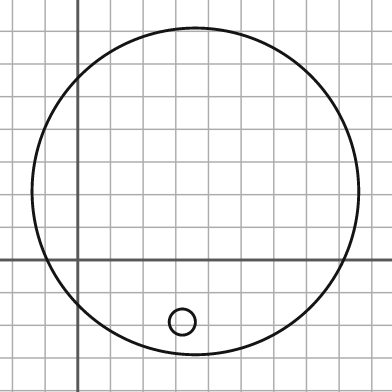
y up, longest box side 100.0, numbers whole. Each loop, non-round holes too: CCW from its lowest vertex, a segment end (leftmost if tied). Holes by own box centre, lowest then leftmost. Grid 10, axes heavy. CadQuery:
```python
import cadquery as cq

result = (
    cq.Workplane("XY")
    .moveTo(36.0, 21.0)
    .circle(50.0)
    .moveTo(32.0, -19.0)
    .circle(4.0)
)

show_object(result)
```